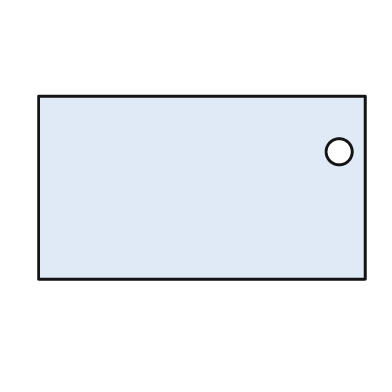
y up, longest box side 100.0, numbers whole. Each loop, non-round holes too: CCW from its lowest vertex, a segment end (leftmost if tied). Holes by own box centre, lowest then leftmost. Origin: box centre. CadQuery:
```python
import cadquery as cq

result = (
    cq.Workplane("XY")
    .moveTo(-50.0, -28.0)
    .lineTo(50.0, -28.0)
    .lineTo(50.0, 28.0)
    .lineTo(-50.0, 28.0)
    .close()
    .moveTo(42.0, 11.0)
    .circle(4.0)
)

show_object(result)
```